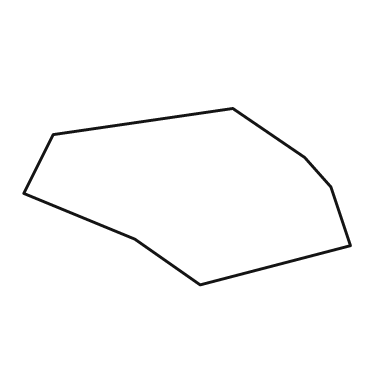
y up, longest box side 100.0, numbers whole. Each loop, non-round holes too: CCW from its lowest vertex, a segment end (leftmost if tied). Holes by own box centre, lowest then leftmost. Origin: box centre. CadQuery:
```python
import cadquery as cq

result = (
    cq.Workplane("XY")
    .moveTo(4.0, -27.0)
    .lineTo(50.0, -15.0)
    .lineTo(44.0, 3.0)
    .lineTo(36.0, 12.0)
    .lineTo(14.0, 27.0)
    .lineTo(-41.0, 19.0)
    .lineTo(-50.0, 1.0)
    .lineTo(-16.0, -13.0)
    .close()
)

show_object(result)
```